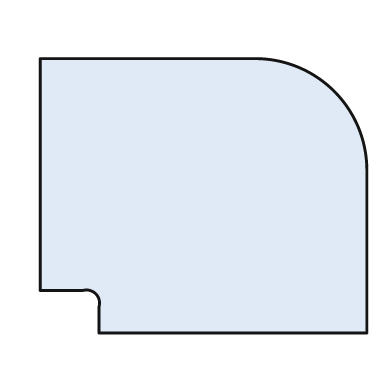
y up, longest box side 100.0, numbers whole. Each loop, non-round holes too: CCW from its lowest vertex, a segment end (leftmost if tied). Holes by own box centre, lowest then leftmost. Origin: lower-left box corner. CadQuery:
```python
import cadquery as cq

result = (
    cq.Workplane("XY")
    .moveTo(18.0, 0.0)
    .lineTo(100.0, 0.0)
    .lineTo(100.0, 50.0)
    .threePointArc((90.0, 74.0), (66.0, 84.0))
    .lineTo(0.0, 84.0)
    .lineTo(0.0, 13.0)
    .lineTo(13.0, 13.0)
    .threePointArc((17.0, 12.0), (18.0, 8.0))
    .close()
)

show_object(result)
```